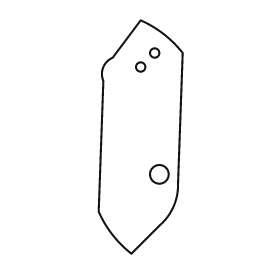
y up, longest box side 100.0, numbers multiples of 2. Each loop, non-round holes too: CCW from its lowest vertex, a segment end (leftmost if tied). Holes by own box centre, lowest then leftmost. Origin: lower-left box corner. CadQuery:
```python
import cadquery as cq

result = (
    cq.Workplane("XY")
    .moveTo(14.0, 0.0)
    .lineTo(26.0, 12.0)
    .threePointArc((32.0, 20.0), (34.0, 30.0))
    .lineTo(36.0, 86.0)
    .threePointArc((28.0, 94.0), (18.0, 100.0))
    .lineTo(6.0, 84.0)
    .threePointArc((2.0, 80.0), (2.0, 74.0))
    .lineTo(0.0, 18.0)
    .threePointArc((6.0, 8.0), (14.0, 0.0))
    .close()
    .moveTo(26.0, 34.0)
    .circle(4.0)
    .moveTo(18.0, 80.0)
    .circle(2.0)
    .moveTo(24.0, 86.0)
    .circle(2.0)
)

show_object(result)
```